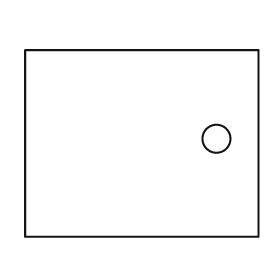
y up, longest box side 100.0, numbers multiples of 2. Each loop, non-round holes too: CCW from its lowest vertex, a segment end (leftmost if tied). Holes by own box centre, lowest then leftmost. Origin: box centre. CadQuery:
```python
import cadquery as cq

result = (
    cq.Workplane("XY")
    .moveTo(-50.0, -40.0)
    .lineTo(50.0, -40.0)
    .lineTo(50.0, 40.0)
    .lineTo(-50.0, 40.0)
    .close()
    .moveTo(32.0, 2.0)
    .circle(6.0)
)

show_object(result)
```